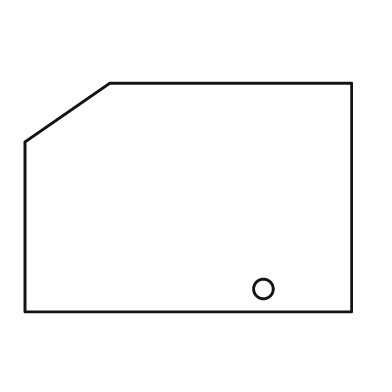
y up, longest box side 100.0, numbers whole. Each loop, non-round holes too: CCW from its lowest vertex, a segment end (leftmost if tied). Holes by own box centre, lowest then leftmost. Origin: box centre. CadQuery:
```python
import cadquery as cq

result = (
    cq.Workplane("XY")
    .moveTo(-50.0, -35.0)
    .lineTo(50.0, -35.0)
    .lineTo(50.0, 35.0)
    .lineTo(-24.0, 35.0)
    .lineTo(-50.0, 17.0)
    .close()
    .moveTo(23.0, -28.0)
    .circle(3.0)
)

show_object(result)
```